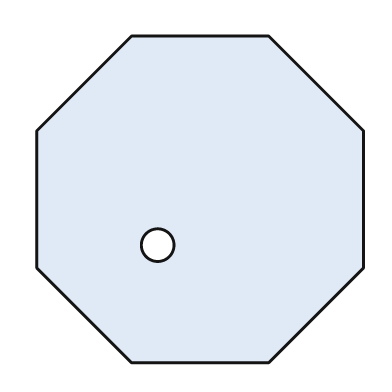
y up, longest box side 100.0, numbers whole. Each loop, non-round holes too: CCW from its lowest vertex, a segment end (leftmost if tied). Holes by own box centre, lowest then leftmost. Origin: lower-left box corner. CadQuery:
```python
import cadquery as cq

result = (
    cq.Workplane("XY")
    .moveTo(29.0, 0.0)
    .lineTo(71.0, 0.0)
    .lineTo(100.0, 29.0)
    .lineTo(100.0, 71.0)
    .lineTo(71.0, 100.0)
    .lineTo(29.0, 100.0)
    .lineTo(0.0, 71.0)
    .lineTo(0.0, 29.0)
    .close()
    .moveTo(37.0, 36.0)
    .circle(5.0)
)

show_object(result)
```